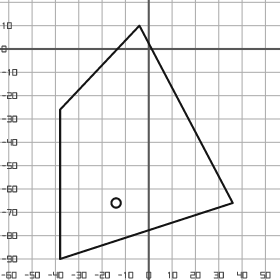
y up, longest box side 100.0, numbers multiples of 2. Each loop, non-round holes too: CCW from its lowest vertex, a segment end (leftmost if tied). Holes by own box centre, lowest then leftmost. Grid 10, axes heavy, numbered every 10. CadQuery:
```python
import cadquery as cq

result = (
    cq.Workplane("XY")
    .moveTo(-38.0, -90.0)
    .lineTo(36.0, -66.0)
    .lineTo(-4.0, 10.0)
    .lineTo(-38.0, -26.0)
    .close()
    .moveTo(-14.0, -66.0)
    .circle(2.0)
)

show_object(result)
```